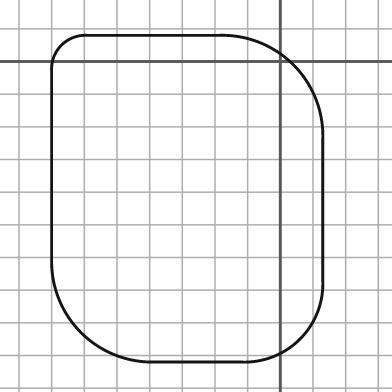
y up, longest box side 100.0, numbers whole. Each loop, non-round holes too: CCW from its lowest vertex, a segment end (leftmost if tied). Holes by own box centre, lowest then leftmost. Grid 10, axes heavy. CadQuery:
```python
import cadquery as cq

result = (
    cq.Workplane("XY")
    .moveTo(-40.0, -92.0)
    .lineTo(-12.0, -92.0)
    .threePointArc((6.0, -85.0), (13.0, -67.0))
    .lineTo(13.0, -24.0)
    .threePointArc((4.0, -1.0), (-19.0, 8.0))
    .lineTo(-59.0, 8.0)
    .threePointArc((-67.0, 5.0), (-70.0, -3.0))
    .lineTo(-70.0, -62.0)
    .threePointArc((-61.0, -83.0), (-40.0, -92.0))
    .close()
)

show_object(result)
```